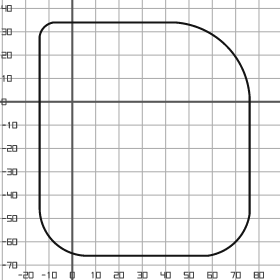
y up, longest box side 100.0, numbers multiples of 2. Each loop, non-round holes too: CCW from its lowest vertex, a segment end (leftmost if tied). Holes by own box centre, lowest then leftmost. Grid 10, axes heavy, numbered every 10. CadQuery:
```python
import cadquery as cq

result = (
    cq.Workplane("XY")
    .moveTo(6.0, -66.0)
    .lineTo(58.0, -66.0)
    .threePointArc((70.0, -60.0), (76.0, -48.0))
    .lineTo(76.0, 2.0)
    .threePointArc((66.0, 24.0), (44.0, 34.0))
    .lineTo(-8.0, 34.0)
    .threePointArc((-12.0, 32.0), (-14.0, 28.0))
    .lineTo(-14.0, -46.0)
    .threePointArc((-8.0, -60.0), (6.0, -66.0))
    .close()
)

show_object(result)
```